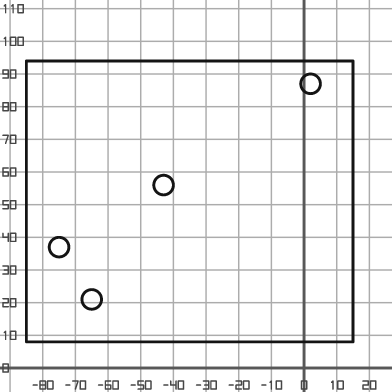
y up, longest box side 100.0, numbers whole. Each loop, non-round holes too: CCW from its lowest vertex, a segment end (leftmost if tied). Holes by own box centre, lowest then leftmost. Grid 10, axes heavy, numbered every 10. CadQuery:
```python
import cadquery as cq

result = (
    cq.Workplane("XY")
    .moveTo(-85.0, 8.0)
    .lineTo(15.0, 8.0)
    .lineTo(15.0, 94.0)
    .lineTo(-85.0, 94.0)
    .close()
    .moveTo(-65.0, 21.0)
    .circle(3.0)
    .moveTo(-75.0, 37.0)
    .circle(3.0)
    .moveTo(-43.0, 56.0)
    .circle(3.0)
    .moveTo(2.0, 87.0)
    .circle(3.0)
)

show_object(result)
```